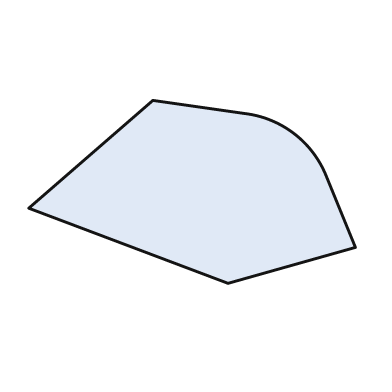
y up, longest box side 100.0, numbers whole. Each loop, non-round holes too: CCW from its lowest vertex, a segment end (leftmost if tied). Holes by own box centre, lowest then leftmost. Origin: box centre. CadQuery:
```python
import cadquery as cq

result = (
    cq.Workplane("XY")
    .moveTo(11.0, -28.0)
    .lineTo(50.0, -17.0)
    .lineTo(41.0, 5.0)
    .threePointArc((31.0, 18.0), (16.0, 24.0))
    .lineTo(-12.0, 28.0)
    .lineTo(-50.0, -5.0)
    .close()
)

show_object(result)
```